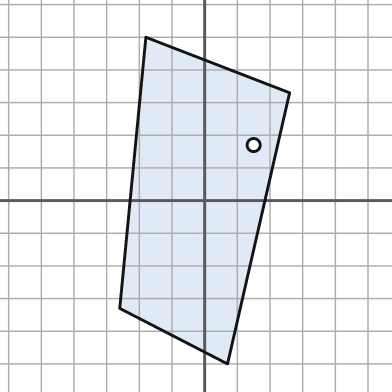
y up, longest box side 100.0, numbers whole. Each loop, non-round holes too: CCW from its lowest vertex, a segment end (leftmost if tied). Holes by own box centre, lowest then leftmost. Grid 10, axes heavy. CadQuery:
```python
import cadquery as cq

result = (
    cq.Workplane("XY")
    .moveTo(7.0, -50.0)
    .lineTo(26.0, 33.0)
    .lineTo(-18.0, 50.0)
    .lineTo(-26.0, -33.0)
    .close()
    .moveTo(15.0, 17.0)
    .circle(2.0)
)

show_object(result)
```